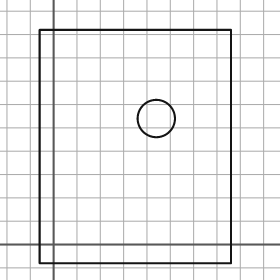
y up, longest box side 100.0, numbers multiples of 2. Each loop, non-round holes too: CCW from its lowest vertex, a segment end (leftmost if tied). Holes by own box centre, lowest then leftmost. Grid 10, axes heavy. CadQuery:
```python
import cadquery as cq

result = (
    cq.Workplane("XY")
    .moveTo(-6.0, -8.0)
    .lineTo(76.0, -8.0)
    .lineTo(76.0, 92.0)
    .lineTo(-6.0, 92.0)
    .close()
    .moveTo(44.0, 54.0)
    .circle(8.0)
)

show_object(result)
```